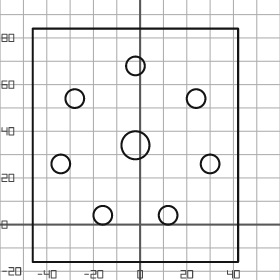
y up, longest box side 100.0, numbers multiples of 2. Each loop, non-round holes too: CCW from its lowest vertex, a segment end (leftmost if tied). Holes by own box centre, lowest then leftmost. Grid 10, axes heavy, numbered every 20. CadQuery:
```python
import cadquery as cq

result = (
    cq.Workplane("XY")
    .moveTo(-46.0, -16.0)
    .lineTo(42.0, -16.0)
    .lineTo(42.0, 84.0)
    .lineTo(-46.0, 84.0)
    .close()
    .moveTo(-16.0, 4.0)
    .circle(4.0)
    .moveTo(12.0, 4.0)
    .circle(4.0)
    .moveTo(-34.0, 26.0)
    .circle(4.0)
    .moveTo(30.0, 26.0)
    .circle(4.0)
    .moveTo(-2.0, 34.0)
    .circle(6.0)
    .moveTo(-28.0, 54.0)
    .circle(4.0)
    .moveTo(24.0, 54.0)
    .circle(4.0)
    .moveTo(-2.0, 68.0)
    .circle(4.0)
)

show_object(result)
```